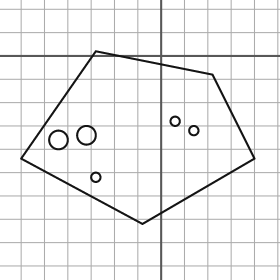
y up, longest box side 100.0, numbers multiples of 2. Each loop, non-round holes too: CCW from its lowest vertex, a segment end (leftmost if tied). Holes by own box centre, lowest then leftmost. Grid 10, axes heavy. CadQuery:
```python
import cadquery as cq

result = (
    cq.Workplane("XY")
    .moveTo(-8.0, -72.0)
    .lineTo(40.0, -44.0)
    .lineTo(22.0, -8.0)
    .lineTo(-28.0, 2.0)
    .lineTo(-60.0, -44.0)
    .close()
    .moveTo(-28.0, -52.0)
    .circle(2.0)
    .moveTo(-44.0, -36.0)
    .circle(4.0)
    .moveTo(-32.0, -34.0)
    .circle(4.0)
    .moveTo(14.0, -32.0)
    .circle(2.0)
    .moveTo(6.0, -28.0)
    .circle(2.0)
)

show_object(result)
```